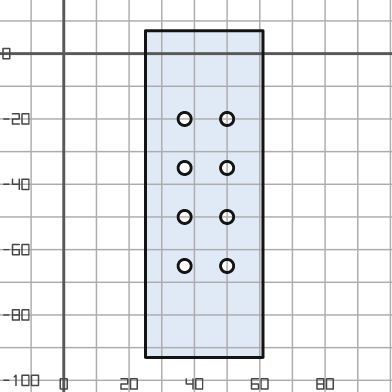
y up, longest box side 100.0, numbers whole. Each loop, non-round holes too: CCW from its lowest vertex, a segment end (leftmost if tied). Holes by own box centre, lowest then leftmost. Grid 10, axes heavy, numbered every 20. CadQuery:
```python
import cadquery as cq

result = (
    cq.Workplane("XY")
    .moveTo(25.0, -93.0)
    .lineTo(61.0, -93.0)
    .lineTo(61.0, 7.0)
    .lineTo(25.0, 7.0)
    .close()
    .moveTo(37.0, -65.0)
    .circle(2.0)
    .moveTo(50.0, -65.0)
    .circle(2.0)
    .moveTo(37.0, -50.0)
    .circle(2.0)
    .moveTo(50.0, -50.0)
    .circle(2.0)
    .moveTo(37.0, -35.0)
    .circle(2.0)
    .moveTo(50.0, -35.0)
    .circle(2.0)
    .moveTo(37.0, -20.0)
    .circle(2.0)
    .moveTo(50.0, -20.0)
    .circle(2.0)
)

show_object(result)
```